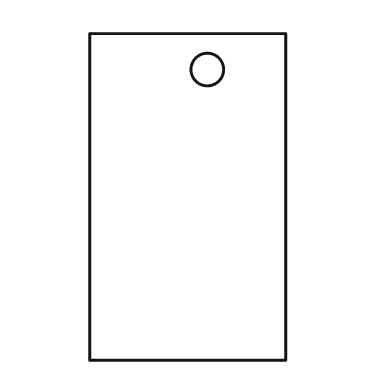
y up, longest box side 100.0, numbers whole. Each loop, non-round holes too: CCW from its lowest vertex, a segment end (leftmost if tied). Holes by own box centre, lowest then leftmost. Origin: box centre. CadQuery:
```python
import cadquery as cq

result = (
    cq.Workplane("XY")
    .moveTo(-30.0, -50.0)
    .lineTo(30.0, -50.0)
    .lineTo(30.0, 50.0)
    .lineTo(-30.0, 50.0)
    .close()
    .moveTo(6.0, 39.0)
    .circle(5.0)
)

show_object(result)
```